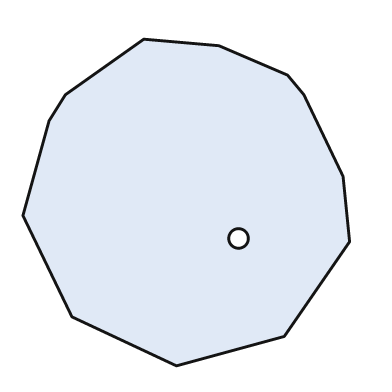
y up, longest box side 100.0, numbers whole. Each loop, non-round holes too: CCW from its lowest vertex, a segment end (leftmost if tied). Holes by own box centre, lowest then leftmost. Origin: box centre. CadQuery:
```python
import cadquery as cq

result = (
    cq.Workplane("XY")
    .moveTo(-3.0, -50.0)
    .lineTo(30.0, -41.0)
    .lineTo(50.0, -12.0)
    .lineTo(48.0, 8.0)
    .lineTo(36.0, 33.0)
    .lineTo(31.0, 39.0)
    .lineTo(10.0, 48.0)
    .lineTo(-13.0, 50.0)
    .lineTo(-37.0, 33.0)
    .lineTo(-42.0, 25.0)
    .lineTo(-50.0, -4.0)
    .lineTo(-35.0, -35.0)
    .close()
    .moveTo(16.0, -11.0)
    .circle(3.0)
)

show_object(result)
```